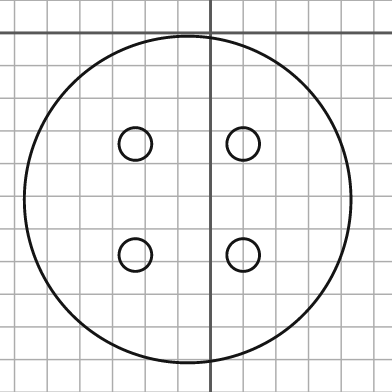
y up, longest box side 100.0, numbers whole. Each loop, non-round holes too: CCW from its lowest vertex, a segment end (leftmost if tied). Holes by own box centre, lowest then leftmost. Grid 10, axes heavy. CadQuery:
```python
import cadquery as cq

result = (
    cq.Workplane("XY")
    .moveTo(-7.0, -51.0)
    .circle(50.0)
    .moveTo(-23.0, -68.0)
    .circle(5.0)
    .moveTo(10.0, -68.0)
    .circle(5.0)
    .moveTo(-23.0, -34.0)
    .circle(5.0)
    .moveTo(10.0, -34.0)
    .circle(5.0)
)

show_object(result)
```